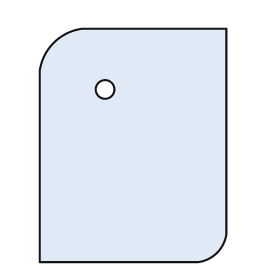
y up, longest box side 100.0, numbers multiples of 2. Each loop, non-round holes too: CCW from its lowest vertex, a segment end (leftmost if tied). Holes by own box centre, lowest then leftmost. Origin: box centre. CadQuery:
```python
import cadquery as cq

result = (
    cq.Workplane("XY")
    .moveTo(-40.0, -50.0)
    .lineTo(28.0, -50.0)
    .threePointArc((36.0, -46.0), (40.0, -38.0))
    .lineTo(40.0, 50.0)
    .lineTo(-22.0, 50.0)
    .threePointArc((-34.0, 44.0), (-40.0, 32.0))
    .close()
    .moveTo(-12.0, 24.0)
    .circle(4.0)
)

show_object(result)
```